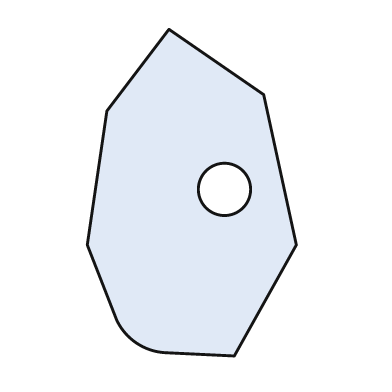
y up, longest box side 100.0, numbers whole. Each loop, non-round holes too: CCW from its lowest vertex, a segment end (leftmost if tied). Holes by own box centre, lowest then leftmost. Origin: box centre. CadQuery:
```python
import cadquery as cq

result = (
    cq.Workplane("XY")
    .moveTo(13.0, -50.0)
    .lineTo(32.0, -16.0)
    .lineTo(22.0, 30.0)
    .lineTo(-7.0, 50.0)
    .lineTo(-26.0, 25.0)
    .lineTo(-32.0, -16.0)
    .lineTo(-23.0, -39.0)
    .threePointArc((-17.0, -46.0), (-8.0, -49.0))
    .close()
    .moveTo(10.0, 1.0)
    .circle(8.0)
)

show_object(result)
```